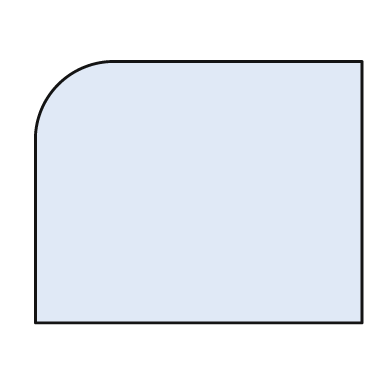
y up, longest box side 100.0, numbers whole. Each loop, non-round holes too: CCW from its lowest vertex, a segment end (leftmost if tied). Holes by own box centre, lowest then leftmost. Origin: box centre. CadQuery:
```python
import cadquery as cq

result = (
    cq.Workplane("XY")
    .moveTo(-50.0, -40.0)
    .lineTo(50.0, -40.0)
    .lineTo(50.0, 40.0)
    .lineTo(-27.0, 40.0)
    .threePointArc((-43.0, 33.0), (-50.0, 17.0))
    .close()
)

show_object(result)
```